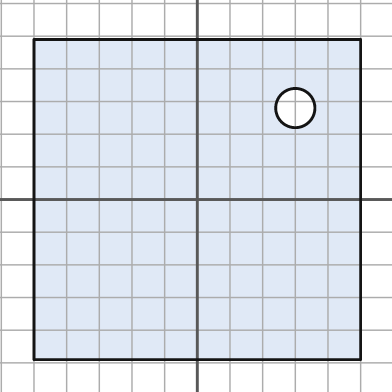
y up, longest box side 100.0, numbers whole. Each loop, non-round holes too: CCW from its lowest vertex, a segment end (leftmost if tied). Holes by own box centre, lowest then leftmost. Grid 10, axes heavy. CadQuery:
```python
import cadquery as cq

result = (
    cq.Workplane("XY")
    .moveTo(-50.0, -49.0)
    .lineTo(50.0, -49.0)
    .lineTo(50.0, 49.0)
    .lineTo(-50.0, 49.0)
    .close()
    .moveTo(30.0, 28.0)
    .circle(6.0)
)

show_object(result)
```